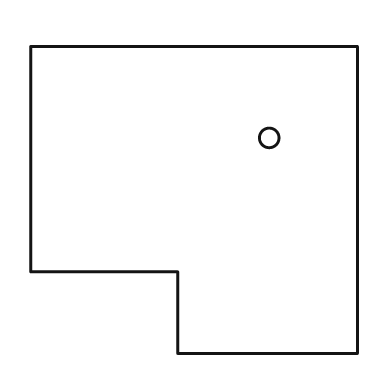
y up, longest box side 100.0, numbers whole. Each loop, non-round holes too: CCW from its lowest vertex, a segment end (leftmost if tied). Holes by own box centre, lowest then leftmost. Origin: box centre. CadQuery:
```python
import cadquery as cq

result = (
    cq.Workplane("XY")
    .moveTo(-5.0, -47.0)
    .lineTo(50.0, -47.0)
    .lineTo(50.0, 47.0)
    .lineTo(-50.0, 47.0)
    .lineTo(-50.0, -22.0)
    .lineTo(-5.0, -22.0)
    .close()
    .moveTo(23.0, 19.0)
    .circle(3.0)
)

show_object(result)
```